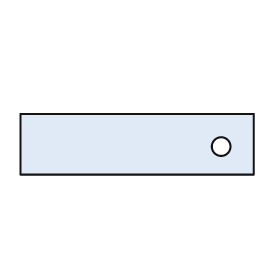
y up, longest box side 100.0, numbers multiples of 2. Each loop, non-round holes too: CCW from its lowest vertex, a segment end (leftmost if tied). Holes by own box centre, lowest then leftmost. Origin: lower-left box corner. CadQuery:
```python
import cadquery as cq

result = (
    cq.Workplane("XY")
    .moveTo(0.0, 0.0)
    .lineTo(100.0, 0.0)
    .lineTo(100.0, 26.0)
    .lineTo(0.0, 26.0)
    .close()
    .moveTo(86.0, 12.0)
    .circle(4.0)
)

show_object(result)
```